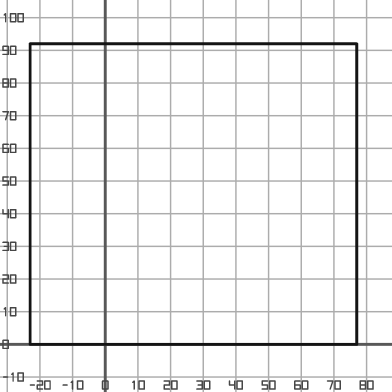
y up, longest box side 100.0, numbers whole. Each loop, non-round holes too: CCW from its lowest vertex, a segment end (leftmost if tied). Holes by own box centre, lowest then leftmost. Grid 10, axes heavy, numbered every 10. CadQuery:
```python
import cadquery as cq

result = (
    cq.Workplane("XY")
    .moveTo(-23.0, 0.0)
    .lineTo(77.0, 0.0)
    .lineTo(77.0, 92.0)
    .lineTo(-23.0, 92.0)
    .close()
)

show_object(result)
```